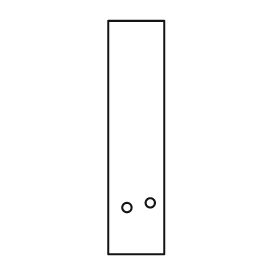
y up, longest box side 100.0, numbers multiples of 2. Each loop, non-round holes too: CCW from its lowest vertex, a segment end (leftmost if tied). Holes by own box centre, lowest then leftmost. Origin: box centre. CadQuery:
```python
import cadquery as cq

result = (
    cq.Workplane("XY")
    .moveTo(-12.0, -50.0)
    .lineTo(12.0, -50.0)
    .lineTo(12.0, 50.0)
    .lineTo(-12.0, 50.0)
    .close()
    .moveTo(-4.0, -30.0)
    .circle(2.0)
    .moveTo(6.0, -28.0)
    .circle(2.0)
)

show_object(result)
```